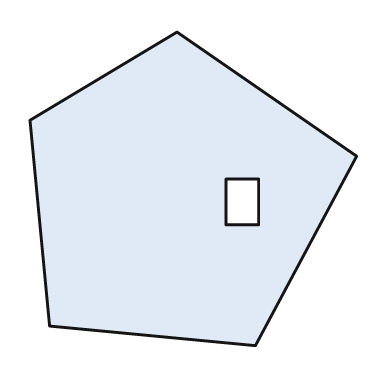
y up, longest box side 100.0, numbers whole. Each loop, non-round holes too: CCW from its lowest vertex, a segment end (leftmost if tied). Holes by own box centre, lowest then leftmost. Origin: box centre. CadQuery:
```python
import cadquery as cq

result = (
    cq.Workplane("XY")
    .moveTo(19.0, -48.0)
    .lineTo(50.0, 10.0)
    .lineTo(-5.0, 48.0)
    .lineTo(-50.0, 21.0)
    .lineTo(-44.0, -42.0)
    .close()
    .moveTo(10.0, -11.0)
    .lineTo(20.0, -11.0)
    .lineTo(20.0, 3.0)
    .lineTo(10.0, 3.0)
    .close()
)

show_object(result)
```